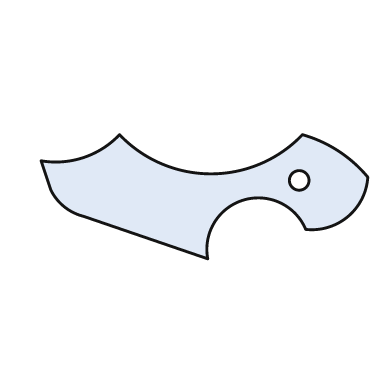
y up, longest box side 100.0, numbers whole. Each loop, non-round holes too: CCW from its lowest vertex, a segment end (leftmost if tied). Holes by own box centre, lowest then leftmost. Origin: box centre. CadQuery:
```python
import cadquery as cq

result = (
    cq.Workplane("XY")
    .moveTo(1.0, -19.0)
    .threePointArc((12.0, -1.0), (31.0, -10.0))
    .threePointArc((44.0, -6.0), (50.0, 6.0))
    .threePointArc((41.0, 14.0), (30.0, 19.0))
    .threePointArc((2.0, 7.0), (-26.0, 19.0))
    .threePointArc((-37.0, 12.0), (-50.0, 11.0))
    .lineTo(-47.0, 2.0)
    .threePointArc((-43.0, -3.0), (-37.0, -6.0))
    .close()
    .moveTo(29.0, 5.0)
    .circle(3.0)
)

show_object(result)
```